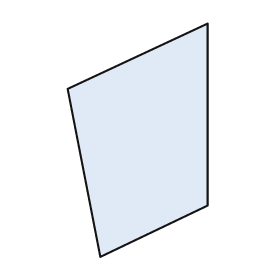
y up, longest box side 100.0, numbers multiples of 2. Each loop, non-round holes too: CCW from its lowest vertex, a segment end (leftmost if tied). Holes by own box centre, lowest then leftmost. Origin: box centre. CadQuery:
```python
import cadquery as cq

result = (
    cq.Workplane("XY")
    .moveTo(-16.0, -50.0)
    .lineTo(30.0, -28.0)
    .lineTo(30.0, 50.0)
    .lineTo(-30.0, 22.0)
    .close()
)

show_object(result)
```